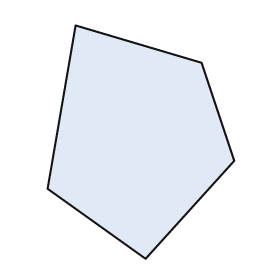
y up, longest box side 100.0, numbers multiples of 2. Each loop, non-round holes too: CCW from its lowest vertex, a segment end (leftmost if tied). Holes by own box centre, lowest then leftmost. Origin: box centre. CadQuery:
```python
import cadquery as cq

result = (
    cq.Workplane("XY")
    .moveTo(2.0, -50.0)
    .lineTo(40.0, -8.0)
    .lineTo(26.0, 34.0)
    .lineTo(-28.0, 50.0)
    .lineTo(-40.0, -20.0)
    .close()
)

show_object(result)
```